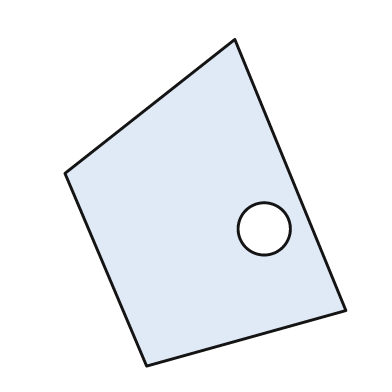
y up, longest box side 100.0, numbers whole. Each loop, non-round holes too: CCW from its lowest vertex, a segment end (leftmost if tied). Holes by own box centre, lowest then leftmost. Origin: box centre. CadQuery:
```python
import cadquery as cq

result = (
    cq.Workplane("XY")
    .moveTo(-18.0, -50.0)
    .lineTo(43.0, -33.0)
    .lineTo(9.0, 50.0)
    .lineTo(-43.0, 9.0)
    .close()
    .moveTo(18.0, -8.0)
    .circle(8.0)
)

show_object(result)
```